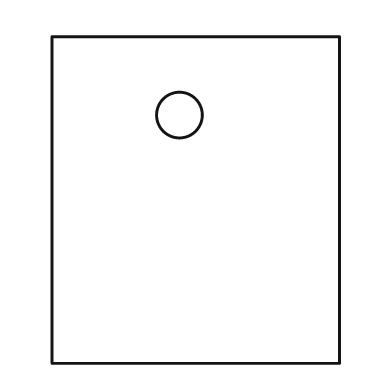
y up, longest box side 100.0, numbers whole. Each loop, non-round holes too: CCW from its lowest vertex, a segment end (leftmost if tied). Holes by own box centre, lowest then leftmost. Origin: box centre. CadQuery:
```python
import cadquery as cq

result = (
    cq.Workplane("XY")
    .moveTo(-44.0, -50.0)
    .lineTo(44.0, -50.0)
    .lineTo(44.0, 50.0)
    .lineTo(-44.0, 50.0)
    .close()
    .moveTo(-5.0, 26.0)
    .circle(7.0)
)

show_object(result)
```